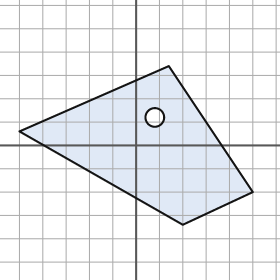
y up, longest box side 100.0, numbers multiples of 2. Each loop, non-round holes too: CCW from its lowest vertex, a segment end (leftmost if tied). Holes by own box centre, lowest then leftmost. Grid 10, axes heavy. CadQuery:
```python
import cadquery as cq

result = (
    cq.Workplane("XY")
    .moveTo(20.0, -34.0)
    .lineTo(50.0, -20.0)
    .lineTo(14.0, 34.0)
    .lineTo(-50.0, 6.0)
    .close()
    .moveTo(8.0, 12.0)
    .circle(4.0)
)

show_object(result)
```